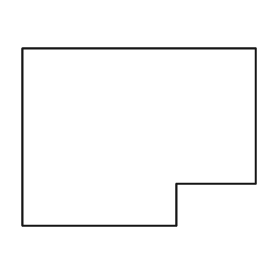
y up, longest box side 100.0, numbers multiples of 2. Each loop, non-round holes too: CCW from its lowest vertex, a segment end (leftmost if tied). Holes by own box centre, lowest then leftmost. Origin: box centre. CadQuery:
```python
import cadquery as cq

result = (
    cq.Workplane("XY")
    .moveTo(-50.0, -38.0)
    .lineTo(16.0, -38.0)
    .lineTo(16.0, -20.0)
    .lineTo(50.0, -20.0)
    .lineTo(50.0, 38.0)
    .lineTo(-50.0, 38.0)
    .close()
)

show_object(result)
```